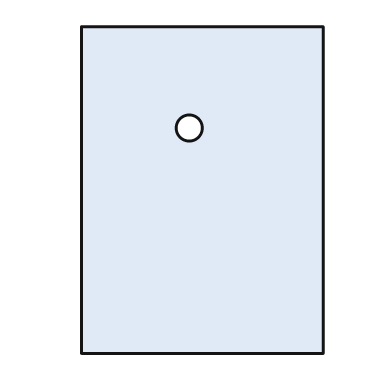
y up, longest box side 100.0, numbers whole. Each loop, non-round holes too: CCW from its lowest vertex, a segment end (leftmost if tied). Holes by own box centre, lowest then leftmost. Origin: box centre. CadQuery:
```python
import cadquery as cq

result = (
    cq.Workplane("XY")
    .moveTo(-37.0, -50.0)
    .lineTo(37.0, -50.0)
    .lineTo(37.0, 50.0)
    .lineTo(-37.0, 50.0)
    .close()
    .moveTo(-4.0, 19.0)
    .circle(4.0)
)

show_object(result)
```